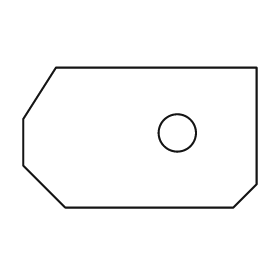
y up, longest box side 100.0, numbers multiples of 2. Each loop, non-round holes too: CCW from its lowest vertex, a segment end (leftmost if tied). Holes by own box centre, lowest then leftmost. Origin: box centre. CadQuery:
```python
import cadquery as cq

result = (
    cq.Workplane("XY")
    .moveTo(-32.0, -30.0)
    .lineTo(40.0, -30.0)
    .lineTo(50.0, -20.0)
    .lineTo(50.0, 30.0)
    .lineTo(-36.0, 30.0)
    .lineTo(-50.0, 8.0)
    .lineTo(-50.0, -12.0)
    .close()
    .moveTo(16.0, 2.0)
    .circle(8.0)
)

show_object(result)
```